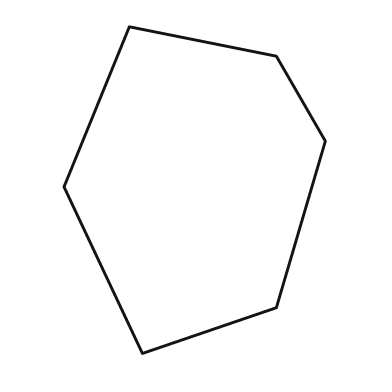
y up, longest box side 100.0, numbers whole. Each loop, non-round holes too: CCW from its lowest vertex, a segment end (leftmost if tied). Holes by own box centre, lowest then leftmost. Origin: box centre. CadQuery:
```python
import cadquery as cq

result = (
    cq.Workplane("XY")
    .moveTo(-16.0, -50.0)
    .lineTo(25.0, -36.0)
    .lineTo(40.0, 15.0)
    .lineTo(25.0, 41.0)
    .lineTo(-20.0, 50.0)
    .lineTo(-40.0, 1.0)
    .close()
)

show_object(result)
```